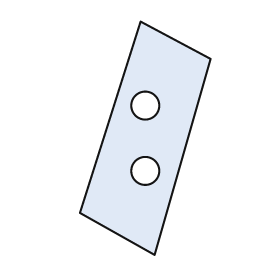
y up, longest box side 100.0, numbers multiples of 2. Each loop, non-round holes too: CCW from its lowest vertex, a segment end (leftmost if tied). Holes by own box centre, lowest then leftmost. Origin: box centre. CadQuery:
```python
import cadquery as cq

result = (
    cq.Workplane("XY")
    .moveTo(4.0, -50.0)
    .lineTo(28.0, 34.0)
    .lineTo(-2.0, 50.0)
    .lineTo(-28.0, -32.0)
    .close()
    .moveTo(0.0, -14.0)
    .circle(6.0)
    .moveTo(0.0, 14.0)
    .circle(6.0)
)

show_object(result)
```